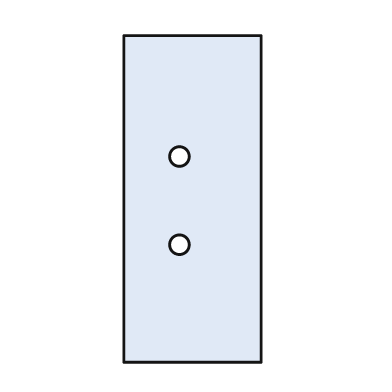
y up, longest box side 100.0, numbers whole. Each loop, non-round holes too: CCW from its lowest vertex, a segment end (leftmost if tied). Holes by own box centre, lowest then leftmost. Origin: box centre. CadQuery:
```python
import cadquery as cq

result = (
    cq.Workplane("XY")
    .moveTo(-21.0, -50.0)
    .lineTo(21.0, -50.0)
    .lineTo(21.0, 50.0)
    .lineTo(-21.0, 50.0)
    .close()
    .moveTo(-4.0, -14.0)
    .circle(3.0)
    .moveTo(-4.0, 13.0)
    .circle(3.0)
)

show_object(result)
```